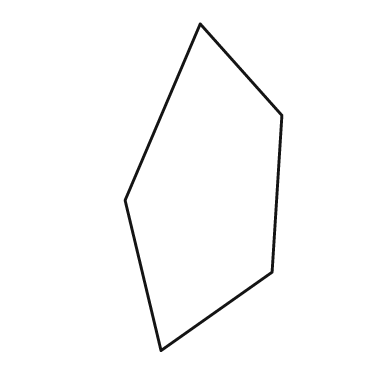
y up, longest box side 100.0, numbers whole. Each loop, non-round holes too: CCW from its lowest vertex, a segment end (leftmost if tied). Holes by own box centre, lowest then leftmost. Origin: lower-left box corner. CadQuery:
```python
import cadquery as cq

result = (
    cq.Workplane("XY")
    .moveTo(11.0, 0.0)
    .lineTo(45.0, 24.0)
    .lineTo(48.0, 72.0)
    .lineTo(23.0, 100.0)
    .lineTo(0.0, 46.0)
    .close()
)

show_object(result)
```